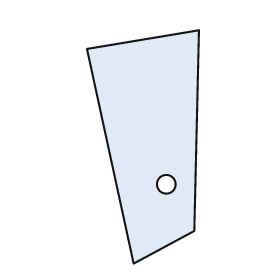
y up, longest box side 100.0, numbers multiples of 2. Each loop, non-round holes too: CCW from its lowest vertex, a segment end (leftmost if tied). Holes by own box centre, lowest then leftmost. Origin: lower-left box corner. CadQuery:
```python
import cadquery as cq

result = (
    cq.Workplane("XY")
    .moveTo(20.0, 0.0)
    .lineTo(46.0, 14.0)
    .lineTo(48.0, 100.0)
    .lineTo(0.0, 92.0)
    .close()
    .moveTo(34.0, 34.0)
    .circle(4.0)
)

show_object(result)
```